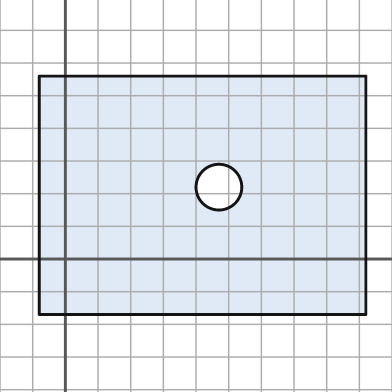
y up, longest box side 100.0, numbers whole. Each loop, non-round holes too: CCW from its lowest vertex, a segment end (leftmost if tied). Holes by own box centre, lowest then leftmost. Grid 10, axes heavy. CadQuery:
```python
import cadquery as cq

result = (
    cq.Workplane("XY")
    .moveTo(-8.0, -17.0)
    .lineTo(92.0, -17.0)
    .lineTo(92.0, 56.0)
    .lineTo(-8.0, 56.0)
    .close()
    .moveTo(47.0, 22.0)
    .circle(7.0)
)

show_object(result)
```